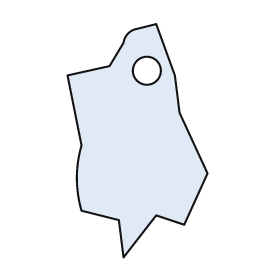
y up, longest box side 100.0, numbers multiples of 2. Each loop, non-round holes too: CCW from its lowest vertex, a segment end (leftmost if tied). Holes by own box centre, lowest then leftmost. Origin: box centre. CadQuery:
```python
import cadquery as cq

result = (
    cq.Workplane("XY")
    .moveTo(-6.0, -50.0)
    .lineTo(8.0, -32.0)
    .lineTo(20.0, -36.0)
    .lineTo(30.0, -14.0)
    .lineTo(18.0, 12.0)
    .lineTo(16.0, 28.0)
    .lineTo(8.0, 50.0)
    .lineTo(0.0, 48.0)
    .threePointArc((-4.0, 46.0), (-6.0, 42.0))
    .lineTo(-12.0, 32.0)
    .lineTo(-30.0, 28.0)
    .lineTo(-24.0, -2.0)
    .threePointArc((-26.0, -16.0), (-24.0, -30.0))
    .lineTo(-8.0, -34.0)
    .close()
    .moveTo(4.0, 30.0)
    .circle(6.0)
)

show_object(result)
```